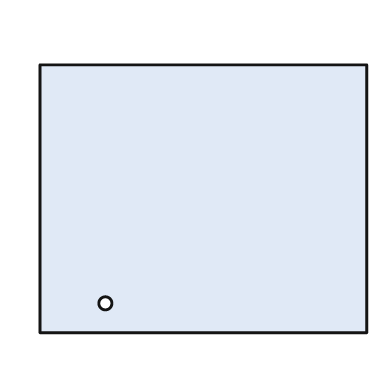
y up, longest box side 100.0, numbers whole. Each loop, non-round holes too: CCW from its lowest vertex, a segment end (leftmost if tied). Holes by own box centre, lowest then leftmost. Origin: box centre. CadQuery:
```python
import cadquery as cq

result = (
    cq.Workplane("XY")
    .moveTo(-50.0, -41.0)
    .lineTo(50.0, -41.0)
    .lineTo(50.0, 41.0)
    .lineTo(-50.0, 41.0)
    .close()
    .moveTo(-30.0, -32.0)
    .circle(2.0)
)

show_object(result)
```